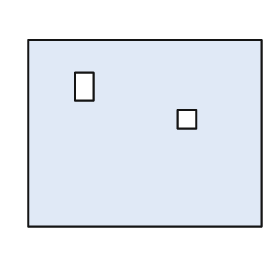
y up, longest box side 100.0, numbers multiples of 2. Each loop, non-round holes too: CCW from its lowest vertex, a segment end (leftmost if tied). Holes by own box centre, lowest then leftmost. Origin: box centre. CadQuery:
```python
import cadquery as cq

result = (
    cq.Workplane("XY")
    .moveTo(-50.0, -40.0)
    .lineTo(50.0, -40.0)
    .lineTo(50.0, 40.0)
    .lineTo(-50.0, 40.0)
    .close()
    .moveTo(14.0, 2.0)
    .lineTo(22.0, 2.0)
    .lineTo(22.0, 10.0)
    .lineTo(14.0, 10.0)
    .close()
    .moveTo(-30.0, 14.0)
    .lineTo(-22.0, 14.0)
    .lineTo(-22.0, 26.0)
    .lineTo(-30.0, 26.0)
    .close()
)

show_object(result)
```